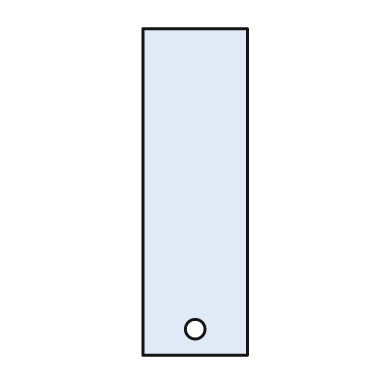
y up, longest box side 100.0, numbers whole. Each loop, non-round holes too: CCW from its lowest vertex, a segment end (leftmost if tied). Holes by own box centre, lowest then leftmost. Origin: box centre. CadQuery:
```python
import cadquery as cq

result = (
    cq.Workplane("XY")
    .moveTo(-16.0, -50.0)
    .lineTo(16.0, -50.0)
    .lineTo(16.0, 50.0)
    .lineTo(-16.0, 50.0)
    .close()
    .moveTo(0.0, -42.0)
    .circle(3.0)
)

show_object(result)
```